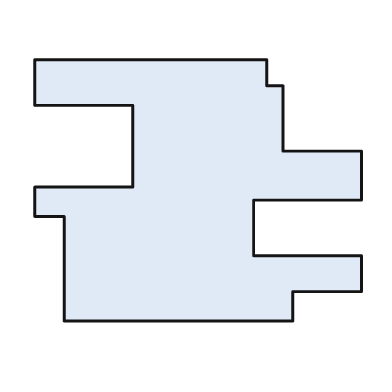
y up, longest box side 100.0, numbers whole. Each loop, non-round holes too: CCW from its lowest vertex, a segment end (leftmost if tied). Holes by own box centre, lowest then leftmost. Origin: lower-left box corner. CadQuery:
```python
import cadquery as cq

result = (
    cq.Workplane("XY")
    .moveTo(9.0, 0.0)
    .lineTo(79.0, 0.0)
    .lineTo(79.0, 9.0)
    .lineTo(100.0, 9.0)
    .lineTo(100.0, 20.0)
    .lineTo(67.0, 20.0)
    .lineTo(67.0, 37.0)
    .lineTo(100.0, 37.0)
    .lineTo(100.0, 52.0)
    .lineTo(76.0, 52.0)
    .lineTo(76.0, 72.0)
    .lineTo(71.0, 72.0)
    .lineTo(71.0, 80.0)
    .lineTo(0.0, 80.0)
    .lineTo(0.0, 66.0)
    .lineTo(30.0, 66.0)
    .lineTo(30.0, 41.0)
    .lineTo(0.0, 41.0)
    .lineTo(0.0, 32.0)
    .lineTo(9.0, 32.0)
    .close()
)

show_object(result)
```